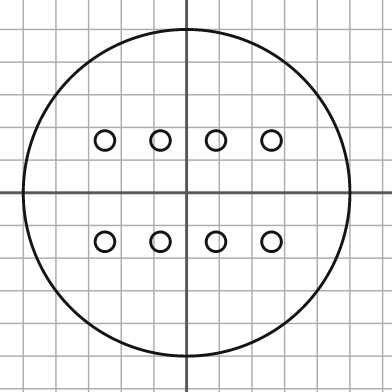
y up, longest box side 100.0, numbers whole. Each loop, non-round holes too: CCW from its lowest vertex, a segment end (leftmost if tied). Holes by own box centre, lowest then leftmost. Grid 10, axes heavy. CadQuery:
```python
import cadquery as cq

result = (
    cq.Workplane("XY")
    .moveTo(0.0, 0.0)
    .circle(50.0)
    .moveTo(-25.0, -15.0)
    .circle(3.0)
    .moveTo(-8.0, -15.0)
    .circle(3.0)
    .moveTo(9.0, -15.0)
    .circle(3.0)
    .moveTo(26.0, -15.0)
    .circle(3.0)
    .moveTo(-25.0, 16.0)
    .circle(3.0)
    .moveTo(-8.0, 16.0)
    .circle(3.0)
    .moveTo(9.0, 16.0)
    .circle(3.0)
    .moveTo(26.0, 16.0)
    .circle(3.0)
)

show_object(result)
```